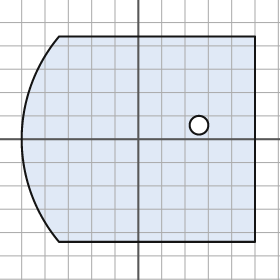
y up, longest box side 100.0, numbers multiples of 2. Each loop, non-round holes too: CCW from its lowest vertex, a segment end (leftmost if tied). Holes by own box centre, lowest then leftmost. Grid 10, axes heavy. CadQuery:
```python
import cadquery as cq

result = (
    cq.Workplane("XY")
    .moveTo(-34.0, -44.0)
    .lineTo(50.0, -44.0)
    .lineTo(50.0, 44.0)
    .lineTo(-34.0, 44.0)
    .threePointArc((-50.0, 0.0), (-34.0, -44.0))
    .close()
    .moveTo(26.0, 6.0)
    .circle(4.0)
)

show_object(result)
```